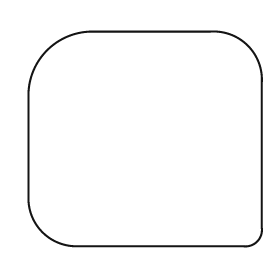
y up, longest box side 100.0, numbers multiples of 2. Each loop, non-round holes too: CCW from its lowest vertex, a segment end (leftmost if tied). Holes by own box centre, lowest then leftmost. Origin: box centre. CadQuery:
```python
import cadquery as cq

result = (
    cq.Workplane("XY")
    .moveTo(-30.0, -46.0)
    .lineTo(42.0, -46.0)
    .threePointArc((48.0, -44.0), (50.0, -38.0))
    .lineTo(50.0, 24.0)
    .threePointArc((44.0, 40.0), (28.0, 46.0))
    .lineTo(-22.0, 46.0)
    .threePointArc((-42.0, 38.0), (-50.0, 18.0))
    .lineTo(-50.0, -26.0)
    .threePointArc((-44.0, -40.0), (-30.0, -46.0))
    .close()
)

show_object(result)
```